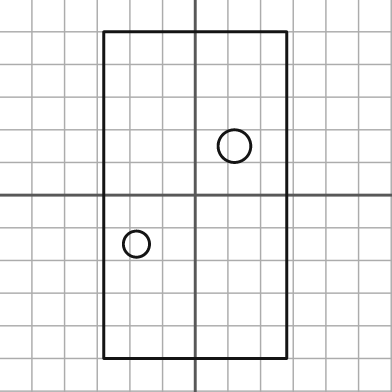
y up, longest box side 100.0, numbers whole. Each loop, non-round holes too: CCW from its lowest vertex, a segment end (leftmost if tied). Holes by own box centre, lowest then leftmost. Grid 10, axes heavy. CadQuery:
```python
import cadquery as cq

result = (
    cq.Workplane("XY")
    .moveTo(-28.0, -50.0)
    .lineTo(28.0, -50.0)
    .lineTo(28.0, 50.0)
    .lineTo(-28.0, 50.0)
    .close()
    .moveTo(-18.0, -15.0)
    .circle(4.0)
    .moveTo(12.0, 15.0)
    .circle(5.0)
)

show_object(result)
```